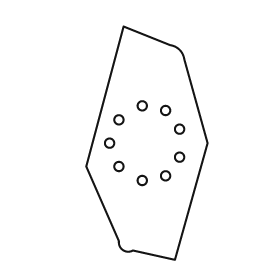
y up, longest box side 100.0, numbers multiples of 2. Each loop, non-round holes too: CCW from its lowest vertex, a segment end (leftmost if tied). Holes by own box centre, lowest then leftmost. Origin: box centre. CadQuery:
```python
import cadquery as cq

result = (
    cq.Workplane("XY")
    .moveTo(12.0, -50.0)
    .lineTo(26.0, 0.0)
    .lineTo(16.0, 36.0)
    .threePointArc((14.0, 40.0), (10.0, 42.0))
    .lineTo(-10.0, 50.0)
    .lineTo(-26.0, -10.0)
    .lineTo(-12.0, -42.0)
    .threePointArc((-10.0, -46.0), (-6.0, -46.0))
    .close()
    .moveTo(-2.0, -16.0)
    .circle(2.0)
    .moveTo(8.0, -14.0)
    .circle(2.0)
    .moveTo(-12.0, -10.0)
    .circle(2.0)
    .moveTo(14.0, -6.0)
    .circle(2.0)
    .moveTo(-16.0, 0.0)
    .circle(2.0)
    .moveTo(14.0, 6.0)
    .circle(2.0)
    .moveTo(-12.0, 10.0)
    .circle(2.0)
    .moveTo(8.0, 14.0)
    .circle(2.0)
    .moveTo(-2.0, 16.0)
    .circle(2.0)
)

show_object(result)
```